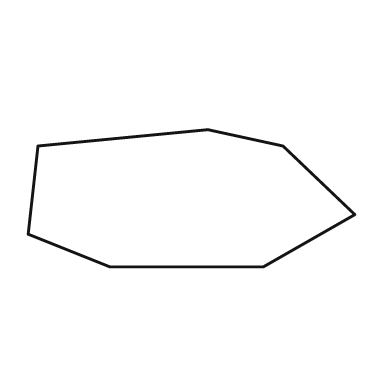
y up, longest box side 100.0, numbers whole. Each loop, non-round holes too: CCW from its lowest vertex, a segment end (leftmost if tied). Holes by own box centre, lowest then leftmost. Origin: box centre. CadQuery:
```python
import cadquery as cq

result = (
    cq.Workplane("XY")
    .moveTo(-25.0, -21.0)
    .lineTo(22.0, -21.0)
    .lineTo(50.0, -5.0)
    .lineTo(28.0, 16.0)
    .lineTo(5.0, 21.0)
    .lineTo(-47.0, 16.0)
    .lineTo(-50.0, -11.0)
    .close()
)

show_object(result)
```